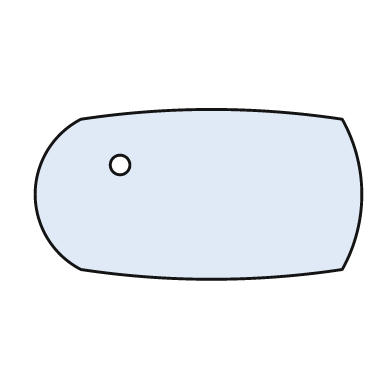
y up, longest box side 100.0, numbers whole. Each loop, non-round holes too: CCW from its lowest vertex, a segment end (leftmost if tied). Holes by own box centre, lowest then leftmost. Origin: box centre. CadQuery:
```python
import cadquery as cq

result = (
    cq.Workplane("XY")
    .moveTo(-36.0, -23.0)
    .threePointArc((4.0, -26.0), (44.0, -23.0))
    .threePointArc((50.0, 0.0), (44.0, 23.0))
    .threePointArc((4.0, 26.0), (-36.0, 23.0))
    .threePointArc((-50.0, 0.0), (-36.0, -23.0))
    .close()
    .moveTo(-24.0, 9.0)
    .circle(3.0)
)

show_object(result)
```